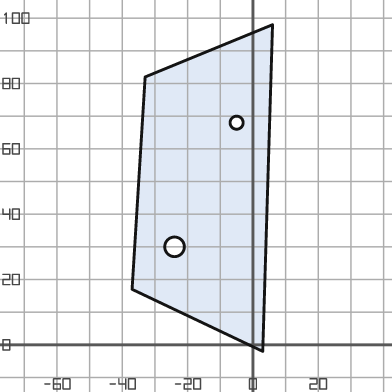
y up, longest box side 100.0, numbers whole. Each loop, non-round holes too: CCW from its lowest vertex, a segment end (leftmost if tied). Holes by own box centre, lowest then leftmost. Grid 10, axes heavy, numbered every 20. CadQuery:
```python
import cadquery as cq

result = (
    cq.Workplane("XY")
    .moveTo(3.0, -2.0)
    .lineTo(6.0, 98.0)
    .lineTo(-33.0, 82.0)
    .lineTo(-37.0, 17.0)
    .close()
    .moveTo(-24.0, 30.0)
    .circle(3.0)
    .moveTo(-5.0, 68.0)
    .circle(2.0)
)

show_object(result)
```